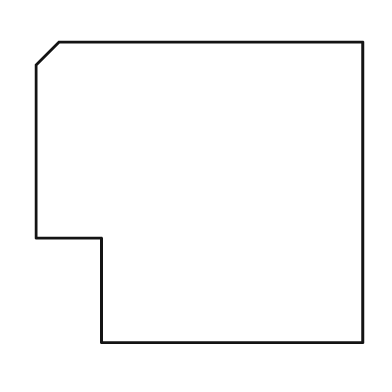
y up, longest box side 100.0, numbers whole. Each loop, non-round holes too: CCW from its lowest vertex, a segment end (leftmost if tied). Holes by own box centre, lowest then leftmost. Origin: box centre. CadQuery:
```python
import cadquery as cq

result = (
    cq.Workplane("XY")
    .moveTo(-30.0, -46.0)
    .lineTo(50.0, -46.0)
    .lineTo(50.0, 46.0)
    .lineTo(-43.0, 46.0)
    .lineTo(-50.0, 39.0)
    .lineTo(-50.0, -14.0)
    .lineTo(-30.0, -14.0)
    .close()
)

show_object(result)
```